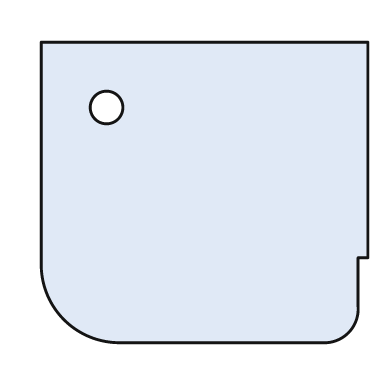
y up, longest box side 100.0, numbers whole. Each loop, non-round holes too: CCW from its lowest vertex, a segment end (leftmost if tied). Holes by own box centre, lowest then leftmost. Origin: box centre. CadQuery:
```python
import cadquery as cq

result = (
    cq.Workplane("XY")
    .moveTo(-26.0, -46.0)
    .lineTo(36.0, -46.0)
    .threePointArc((44.0, -43.0), (47.0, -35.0))
    .lineTo(47.0, -20.0)
    .lineTo(50.0, -20.0)
    .lineTo(50.0, 46.0)
    .lineTo(-50.0, 46.0)
    .lineTo(-50.0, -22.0)
    .threePointArc((-43.0, -39.0), (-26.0, -46.0))
    .close()
    .moveTo(-30.0, 26.0)
    .circle(5.0)
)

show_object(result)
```